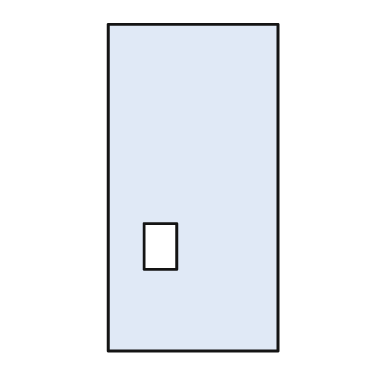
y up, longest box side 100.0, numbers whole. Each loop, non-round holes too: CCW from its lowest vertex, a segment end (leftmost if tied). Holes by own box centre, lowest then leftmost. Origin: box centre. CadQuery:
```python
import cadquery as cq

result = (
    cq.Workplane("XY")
    .moveTo(-26.0, -50.0)
    .lineTo(26.0, -50.0)
    .lineTo(26.0, 50.0)
    .lineTo(-26.0, 50.0)
    .close()
    .moveTo(-15.0, -25.0)
    .lineTo(-5.0, -25.0)
    .lineTo(-5.0, -11.0)
    .lineTo(-15.0, -11.0)
    .close()
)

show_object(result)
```